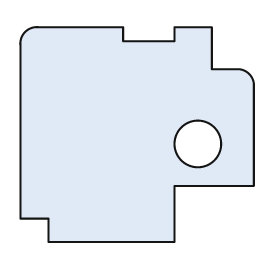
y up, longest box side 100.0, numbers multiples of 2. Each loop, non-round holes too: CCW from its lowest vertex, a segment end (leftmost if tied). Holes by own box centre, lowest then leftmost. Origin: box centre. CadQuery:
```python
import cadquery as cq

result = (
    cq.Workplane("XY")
    .moveTo(-38.0, -46.0)
    .lineTo(16.0, -46.0)
    .lineTo(16.0, -22.0)
    .lineTo(50.0, -22.0)
    .lineTo(50.0, 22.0)
    .threePointArc((48.0, 26.0), (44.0, 28.0))
    .lineTo(32.0, 28.0)
    .lineTo(32.0, 46.0)
    .lineTo(16.0, 46.0)
    .lineTo(16.0, 40.0)
    .lineTo(-6.0, 40.0)
    .lineTo(-6.0, 46.0)
    .lineTo(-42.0, 46.0)
    .threePointArc((-48.0, 44.0), (-50.0, 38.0))
    .lineTo(-50.0, -36.0)
    .lineTo(-38.0, -36.0)
    .close()
    .moveTo(26.0, -4.0)
    .circle(10.0)
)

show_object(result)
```